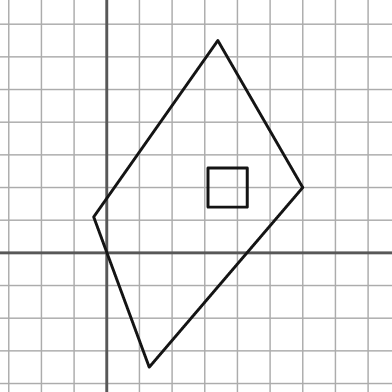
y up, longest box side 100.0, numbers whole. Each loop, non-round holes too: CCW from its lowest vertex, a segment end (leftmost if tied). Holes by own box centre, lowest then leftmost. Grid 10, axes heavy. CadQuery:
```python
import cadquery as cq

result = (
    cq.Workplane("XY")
    .moveTo(13.0, -35.0)
    .lineTo(60.0, 20.0)
    .lineTo(34.0, 65.0)
    .lineTo(-4.0, 11.0)
    .close()
    .moveTo(31.0, 14.0)
    .lineTo(43.0, 14.0)
    .lineTo(43.0, 26.0)
    .lineTo(31.0, 26.0)
    .close()
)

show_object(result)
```